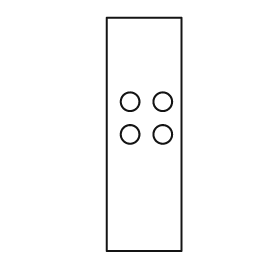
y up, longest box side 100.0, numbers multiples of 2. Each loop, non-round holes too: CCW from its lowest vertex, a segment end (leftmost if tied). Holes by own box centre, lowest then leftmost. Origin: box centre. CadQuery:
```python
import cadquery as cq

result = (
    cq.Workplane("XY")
    .moveTo(-16.0, -50.0)
    .lineTo(16.0, -50.0)
    .lineTo(16.0, 50.0)
    .lineTo(-16.0, 50.0)
    .close()
    .moveTo(-6.0, 0.0)
    .circle(4.0)
    .moveTo(8.0, 0.0)
    .circle(4.0)
    .moveTo(-6.0, 14.0)
    .circle(4.0)
    .moveTo(8.0, 14.0)
    .circle(4.0)
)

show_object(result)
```